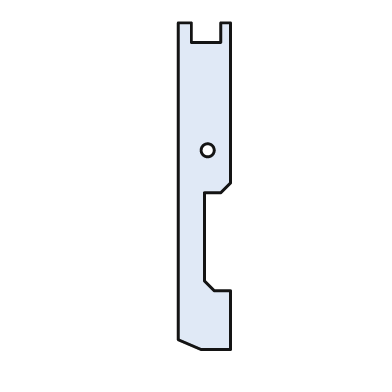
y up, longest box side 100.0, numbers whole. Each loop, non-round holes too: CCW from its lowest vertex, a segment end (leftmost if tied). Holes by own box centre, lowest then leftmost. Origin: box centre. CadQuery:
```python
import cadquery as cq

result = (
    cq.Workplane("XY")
    .moveTo(-1.0, -50.0)
    .lineTo(8.0, -50.0)
    .lineTo(8.0, -32.0)
    .lineTo(3.0, -32.0)
    .lineTo(0.0, -29.0)
    .lineTo(0.0, -2.0)
    .lineTo(5.0, -2.0)
    .lineTo(8.0, 1.0)
    .lineTo(8.0, 50.0)
    .lineTo(5.0, 50.0)
    .lineTo(5.0, 44.0)
    .lineTo(-4.0, 44.0)
    .lineTo(-4.0, 50.0)
    .lineTo(-8.0, 50.0)
    .lineTo(-8.0, -47.0)
    .close()
    .moveTo(1.0, 11.0)
    .circle(2.0)
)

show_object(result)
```